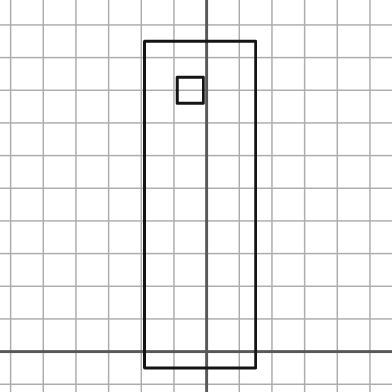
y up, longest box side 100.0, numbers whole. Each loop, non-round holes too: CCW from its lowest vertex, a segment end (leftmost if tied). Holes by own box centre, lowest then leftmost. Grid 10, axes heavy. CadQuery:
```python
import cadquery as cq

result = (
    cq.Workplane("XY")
    .moveTo(-19.0, -5.0)
    .lineTo(15.0, -5.0)
    .lineTo(15.0, 95.0)
    .lineTo(-19.0, 95.0)
    .close()
    .moveTo(-9.0, 76.0)
    .lineTo(-1.0, 76.0)
    .lineTo(-1.0, 84.0)
    .lineTo(-9.0, 84.0)
    .close()
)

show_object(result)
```